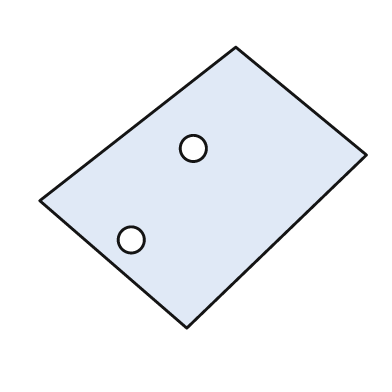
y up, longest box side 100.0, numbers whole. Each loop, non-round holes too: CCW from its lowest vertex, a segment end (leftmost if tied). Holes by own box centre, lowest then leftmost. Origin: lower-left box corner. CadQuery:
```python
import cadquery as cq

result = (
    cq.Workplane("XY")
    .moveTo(45.0, 0.0)
    .lineTo(100.0, 53.0)
    .lineTo(60.0, 86.0)
    .lineTo(0.0, 39.0)
    .close()
    .moveTo(28.0, 27.0)
    .circle(4.0)
    .moveTo(47.0, 55.0)
    .circle(4.0)
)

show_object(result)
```